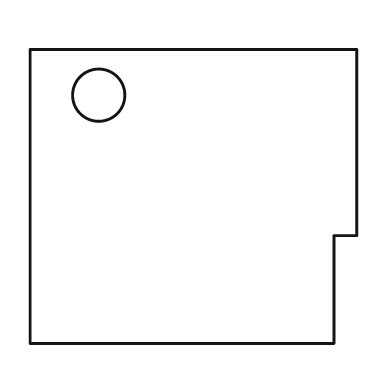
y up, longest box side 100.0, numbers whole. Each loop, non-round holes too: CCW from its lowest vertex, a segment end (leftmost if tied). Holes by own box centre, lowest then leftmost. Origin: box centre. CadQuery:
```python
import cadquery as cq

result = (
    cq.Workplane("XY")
    .moveTo(-50.0, -45.0)
    .lineTo(43.0, -45.0)
    .lineTo(43.0, -12.0)
    .lineTo(50.0, -12.0)
    .lineTo(50.0, 45.0)
    .lineTo(-50.0, 45.0)
    .close()
    .moveTo(-29.0, 31.0)
    .circle(8.0)
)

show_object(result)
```